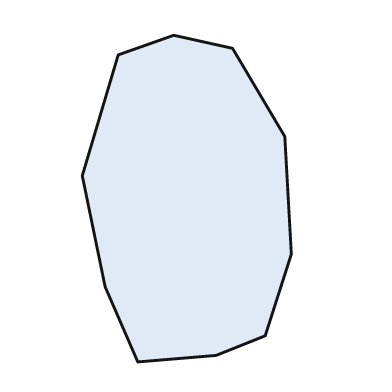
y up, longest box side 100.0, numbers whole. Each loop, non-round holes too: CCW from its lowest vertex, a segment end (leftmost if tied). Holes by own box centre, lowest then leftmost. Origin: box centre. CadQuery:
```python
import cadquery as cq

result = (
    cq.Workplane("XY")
    .moveTo(-15.0, -50.0)
    .lineTo(9.0, -48.0)
    .lineTo(24.0, -42.0)
    .lineTo(32.0, -17.0)
    .lineTo(30.0, 19.0)
    .lineTo(14.0, 46.0)
    .lineTo(-4.0, 50.0)
    .lineTo(-21.0, 44.0)
    .lineTo(-32.0, 7.0)
    .lineTo(-25.0, -27.0)
    .close()
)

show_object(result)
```